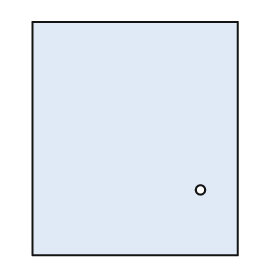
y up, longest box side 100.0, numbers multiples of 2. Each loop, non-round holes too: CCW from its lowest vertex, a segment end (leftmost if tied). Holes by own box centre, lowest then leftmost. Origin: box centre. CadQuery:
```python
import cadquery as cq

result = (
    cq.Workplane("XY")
    .moveTo(-44.0, -50.0)
    .lineTo(44.0, -50.0)
    .lineTo(44.0, 50.0)
    .lineTo(-44.0, 50.0)
    .close()
    .moveTo(28.0, -22.0)
    .circle(2.0)
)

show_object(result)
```